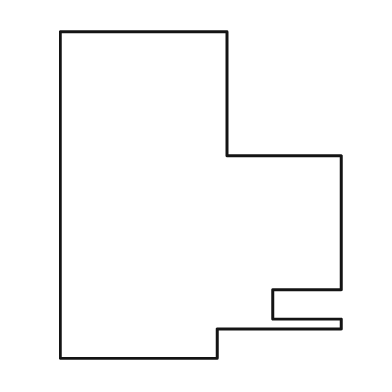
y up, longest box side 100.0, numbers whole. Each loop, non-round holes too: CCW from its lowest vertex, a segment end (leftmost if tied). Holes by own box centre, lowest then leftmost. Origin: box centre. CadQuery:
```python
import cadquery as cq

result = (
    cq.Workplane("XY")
    .moveTo(-43.0, -50.0)
    .lineTo(5.0, -50.0)
    .lineTo(5.0, -41.0)
    .lineTo(43.0, -41.0)
    .lineTo(43.0, -38.0)
    .lineTo(22.0, -38.0)
    .lineTo(22.0, -29.0)
    .lineTo(43.0, -29.0)
    .lineTo(43.0, 12.0)
    .lineTo(8.0, 12.0)
    .lineTo(8.0, 50.0)
    .lineTo(-43.0, 50.0)
    .close()
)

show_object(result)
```